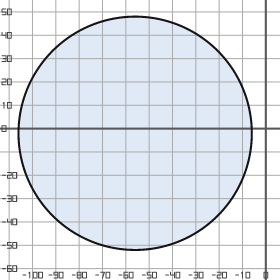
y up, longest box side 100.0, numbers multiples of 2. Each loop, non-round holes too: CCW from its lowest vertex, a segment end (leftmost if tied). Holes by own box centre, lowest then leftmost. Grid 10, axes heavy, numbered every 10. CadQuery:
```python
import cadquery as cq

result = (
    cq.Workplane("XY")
    .moveTo(-56.0, -2.0)
    .circle(50.0)
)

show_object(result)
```